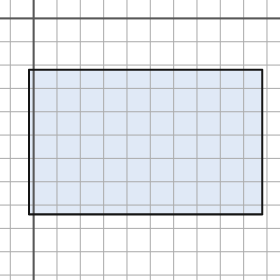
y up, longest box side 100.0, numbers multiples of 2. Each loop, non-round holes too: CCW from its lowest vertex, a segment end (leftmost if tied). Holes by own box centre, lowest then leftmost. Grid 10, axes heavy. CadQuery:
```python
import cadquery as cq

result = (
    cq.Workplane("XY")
    .moveTo(-2.0, -84.0)
    .lineTo(98.0, -84.0)
    .lineTo(98.0, -22.0)
    .lineTo(-2.0, -22.0)
    .close()
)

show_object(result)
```